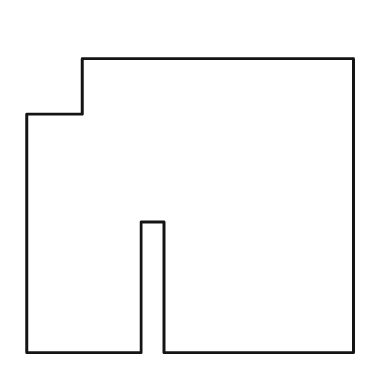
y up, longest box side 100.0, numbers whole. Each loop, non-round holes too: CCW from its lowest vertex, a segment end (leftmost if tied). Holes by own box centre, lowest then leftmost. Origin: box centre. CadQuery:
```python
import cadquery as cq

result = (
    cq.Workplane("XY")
    .moveTo(-50.0, -45.0)
    .lineTo(-15.0, -45.0)
    .lineTo(-15.0, -5.0)
    .lineTo(-8.0, -5.0)
    .lineTo(-8.0, -45.0)
    .lineTo(50.0, -45.0)
    .lineTo(50.0, 45.0)
    .lineTo(-33.0, 45.0)
    .lineTo(-33.0, 28.0)
    .lineTo(-50.0, 28.0)
    .close()
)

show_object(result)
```